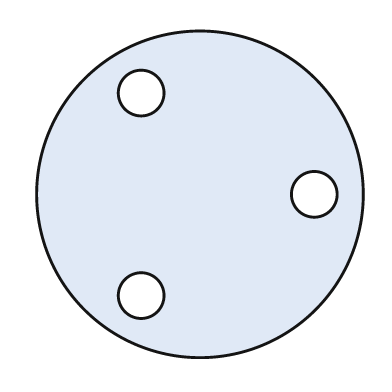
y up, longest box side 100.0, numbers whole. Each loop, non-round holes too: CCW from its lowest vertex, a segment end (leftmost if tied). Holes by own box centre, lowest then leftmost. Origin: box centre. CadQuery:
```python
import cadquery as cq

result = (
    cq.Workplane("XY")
    .moveTo(0.0, 0.0)
    .circle(50.0)
    .moveTo(-18.0, -31.0)
    .circle(7.0)
    .moveTo(35.0, 0.0)
    .circle(7.0)
    .moveTo(-18.0, 31.0)
    .circle(7.0)
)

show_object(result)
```